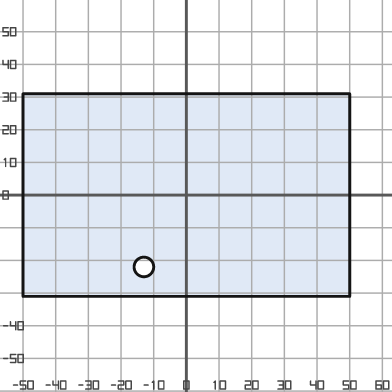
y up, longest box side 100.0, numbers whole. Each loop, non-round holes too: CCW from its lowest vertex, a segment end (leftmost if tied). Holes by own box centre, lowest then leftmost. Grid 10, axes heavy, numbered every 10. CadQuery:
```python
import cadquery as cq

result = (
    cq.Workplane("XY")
    .moveTo(-50.0, -31.0)
    .lineTo(50.0, -31.0)
    .lineTo(50.0, 31.0)
    .lineTo(-50.0, 31.0)
    .close()
    .moveTo(-13.0, -22.0)
    .circle(3.0)
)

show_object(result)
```